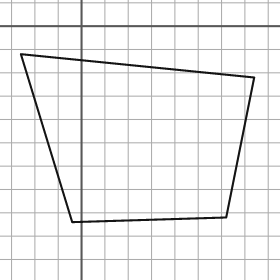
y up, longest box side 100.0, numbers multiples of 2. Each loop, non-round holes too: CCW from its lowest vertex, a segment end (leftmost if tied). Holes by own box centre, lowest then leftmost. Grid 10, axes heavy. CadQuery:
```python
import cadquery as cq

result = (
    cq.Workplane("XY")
    .moveTo(-4.0, -84.0)
    .lineTo(62.0, -82.0)
    .lineTo(74.0, -22.0)
    .lineTo(-26.0, -12.0)
    .close()
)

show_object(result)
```